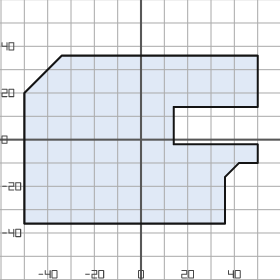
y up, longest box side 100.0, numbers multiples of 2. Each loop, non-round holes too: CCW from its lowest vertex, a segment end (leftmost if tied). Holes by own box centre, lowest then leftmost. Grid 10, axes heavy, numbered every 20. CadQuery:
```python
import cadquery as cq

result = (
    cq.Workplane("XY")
    .moveTo(-50.0, -36.0)
    .lineTo(36.0, -36.0)
    .lineTo(36.0, -16.0)
    .lineTo(42.0, -10.0)
    .lineTo(50.0, -10.0)
    .lineTo(50.0, -2.0)
    .lineTo(14.0, -2.0)
    .lineTo(14.0, 14.0)
    .lineTo(50.0, 14.0)
    .lineTo(50.0, 36.0)
    .lineTo(-34.0, 36.0)
    .lineTo(-50.0, 20.0)
    .close()
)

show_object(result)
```